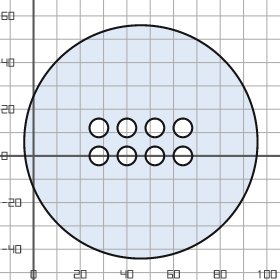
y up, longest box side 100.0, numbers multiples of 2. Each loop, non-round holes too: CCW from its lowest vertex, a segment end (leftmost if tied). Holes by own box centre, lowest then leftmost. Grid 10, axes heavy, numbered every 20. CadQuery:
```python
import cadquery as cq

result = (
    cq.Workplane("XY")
    .moveTo(46.0, 6.0)
    .circle(50.0)
    .moveTo(28.0, 0.0)
    .circle(4.0)
    .moveTo(40.0, 0.0)
    .circle(4.0)
    .moveTo(52.0, 0.0)
    .circle(4.0)
    .moveTo(64.0, 0.0)
    .circle(4.0)
    .moveTo(28.0, 12.0)
    .circle(4.0)
    .moveTo(40.0, 12.0)
    .circle(4.0)
    .moveTo(52.0, 12.0)
    .circle(4.0)
    .moveTo(64.0, 12.0)
    .circle(4.0)
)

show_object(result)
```